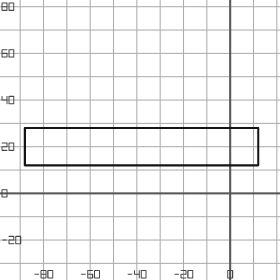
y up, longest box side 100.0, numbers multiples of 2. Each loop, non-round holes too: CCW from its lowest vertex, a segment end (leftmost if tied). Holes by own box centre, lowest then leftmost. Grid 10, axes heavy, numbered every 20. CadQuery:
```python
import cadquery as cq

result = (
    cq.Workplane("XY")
    .moveTo(-88.0, 12.0)
    .lineTo(12.0, 12.0)
    .lineTo(12.0, 28.0)
    .lineTo(-88.0, 28.0)
    .close()
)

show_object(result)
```